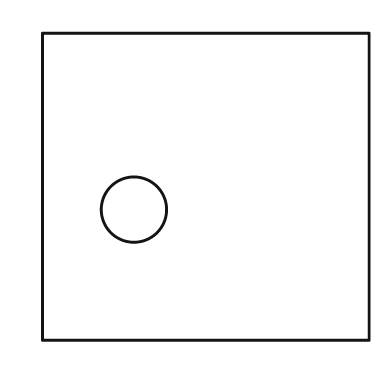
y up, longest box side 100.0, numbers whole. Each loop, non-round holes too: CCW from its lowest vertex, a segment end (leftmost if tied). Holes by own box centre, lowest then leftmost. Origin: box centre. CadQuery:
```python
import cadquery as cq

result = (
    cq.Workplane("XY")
    .moveTo(-50.0, -47.0)
    .lineTo(50.0, -47.0)
    .lineTo(50.0, 47.0)
    .lineTo(-50.0, 47.0)
    .close()
    .moveTo(-22.0, -7.0)
    .circle(10.0)
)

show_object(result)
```